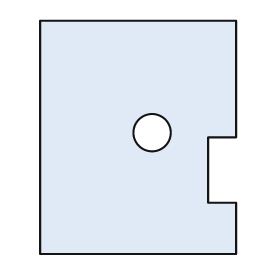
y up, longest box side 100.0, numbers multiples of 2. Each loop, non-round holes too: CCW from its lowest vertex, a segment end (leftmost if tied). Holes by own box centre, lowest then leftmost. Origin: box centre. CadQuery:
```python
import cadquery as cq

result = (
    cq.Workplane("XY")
    .moveTo(-42.0, -50.0)
    .lineTo(42.0, -50.0)
    .lineTo(42.0, -28.0)
    .lineTo(30.0, -28.0)
    .lineTo(30.0, 0.0)
    .lineTo(42.0, 0.0)
    .lineTo(42.0, 50.0)
    .lineTo(-42.0, 50.0)
    .close()
    .moveTo(6.0, 2.0)
    .circle(8.0)
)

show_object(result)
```